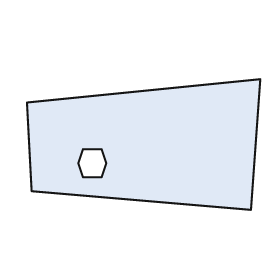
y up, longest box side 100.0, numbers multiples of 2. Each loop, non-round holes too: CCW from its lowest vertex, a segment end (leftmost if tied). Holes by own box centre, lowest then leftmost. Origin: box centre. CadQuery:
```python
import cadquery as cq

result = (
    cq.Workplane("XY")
    .moveTo(46.0, -28.0)
    .lineTo(50.0, 28.0)
    .lineTo(-50.0, 18.0)
    .lineTo(-48.0, -20.0)
    .close()
    .moveTo(-26.0, -14.0)
    .lineTo(-18.0, -14.0)
    .lineTo(-16.0, -8.0)
    .lineTo(-18.0, -2.0)
    .lineTo(-26.0, -2.0)
    .lineTo(-28.0, -8.0)
    .close()
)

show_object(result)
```